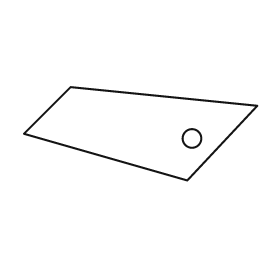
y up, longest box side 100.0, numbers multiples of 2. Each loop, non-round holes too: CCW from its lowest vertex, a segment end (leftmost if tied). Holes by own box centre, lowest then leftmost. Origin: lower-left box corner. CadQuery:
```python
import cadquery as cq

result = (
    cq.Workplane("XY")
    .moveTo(70.0, 0.0)
    .lineTo(100.0, 32.0)
    .lineTo(20.0, 40.0)
    .lineTo(0.0, 20.0)
    .close()
    .moveTo(72.0, 18.0)
    .circle(4.0)
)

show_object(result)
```